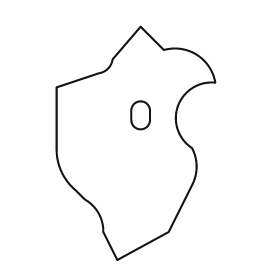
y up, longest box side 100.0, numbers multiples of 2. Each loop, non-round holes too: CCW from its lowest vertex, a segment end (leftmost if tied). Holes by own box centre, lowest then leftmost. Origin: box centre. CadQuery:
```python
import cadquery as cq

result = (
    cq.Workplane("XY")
    .moveTo(-8.0, -50.0)
    .lineTo(14.0, -38.0)
    .lineTo(24.0, -18.0)
    .threePointArc((26.0, -10.0), (24.0, -2.0))
    .threePointArc((18.0, 16.0), (34.0, 26.0))
    .threePointArc((26.0, 38.0), (12.0, 40.0))
    .lineTo(2.0, 50.0)
    .lineTo(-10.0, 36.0)
    .threePointArc((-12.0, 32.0), (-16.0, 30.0))
    .lineTo(-34.0, 24.0)
    .lineTo(-34.0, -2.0)
    .threePointArc((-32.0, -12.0), (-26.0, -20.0))
    .lineTo(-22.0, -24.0)
    .threePointArc((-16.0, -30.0), (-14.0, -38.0))
    .close()
    .moveTo(-2.0, 10.0)
    .threePointArc((2.0, 6.0), (6.0, 10.0))
    .lineTo(6.0, 14.0)
    .threePointArc((2.0, 18.0), (-2.0, 14.0))
    .close()
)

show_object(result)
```